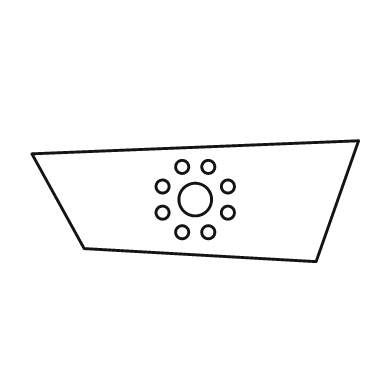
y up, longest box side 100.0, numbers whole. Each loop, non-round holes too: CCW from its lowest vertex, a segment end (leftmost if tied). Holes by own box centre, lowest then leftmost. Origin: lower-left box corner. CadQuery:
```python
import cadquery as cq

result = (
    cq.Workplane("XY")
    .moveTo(87.0, 0.0)
    .lineTo(100.0, 37.0)
    .lineTo(0.0, 33.0)
    .lineTo(16.0, 4.0)
    .close()
    .moveTo(46.0, 9.0)
    .circle(2.0)
    .moveTo(54.0, 9.0)
    .circle(2.0)
    .moveTo(40.0, 15.0)
    .circle(2.0)
    .moveTo(60.0, 15.0)
    .circle(2.0)
    .moveTo(50.0, 19.0)
    .circle(5.0)
    .moveTo(40.0, 23.0)
    .circle(2.0)
    .moveTo(60.0, 23.0)
    .circle(2.0)
    .moveTo(46.0, 29.0)
    .circle(2.0)
    .moveTo(54.0, 29.0)
    .circle(2.0)
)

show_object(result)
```